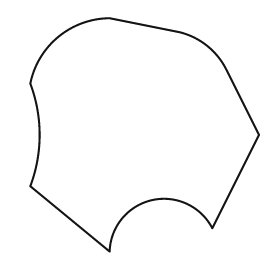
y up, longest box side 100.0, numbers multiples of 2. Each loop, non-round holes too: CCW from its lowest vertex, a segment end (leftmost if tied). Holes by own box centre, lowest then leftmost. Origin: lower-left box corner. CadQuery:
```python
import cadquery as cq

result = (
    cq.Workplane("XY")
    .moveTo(34.0, 0.0)
    .threePointArc((52.0, 22.0), (78.0, 10.0))
    .lineTo(98.0, 50.0)
    .lineTo(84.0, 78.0)
    .threePointArc((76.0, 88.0), (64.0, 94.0))
    .lineTo(34.0, 100.0)
    .threePointArc((12.0, 92.0), (0.0, 72.0))
    .threePointArc((4.0, 50.0), (0.0, 28.0))
    .close()
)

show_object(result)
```